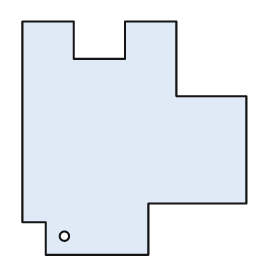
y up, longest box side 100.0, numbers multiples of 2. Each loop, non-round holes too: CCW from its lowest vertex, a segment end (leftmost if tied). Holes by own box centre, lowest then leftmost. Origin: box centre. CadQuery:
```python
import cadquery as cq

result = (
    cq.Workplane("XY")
    .moveTo(-38.0, -50.0)
    .lineTo(6.0, -50.0)
    .lineTo(6.0, -28.0)
    .lineTo(48.0, -28.0)
    .lineTo(48.0, 18.0)
    .lineTo(18.0, 18.0)
    .lineTo(18.0, 50.0)
    .lineTo(-4.0, 50.0)
    .lineTo(-4.0, 34.0)
    .lineTo(-26.0, 34.0)
    .lineTo(-26.0, 50.0)
    .lineTo(-48.0, 50.0)
    .lineTo(-48.0, -36.0)
    .lineTo(-38.0, -36.0)
    .close()
    .moveTo(-30.0, -42.0)
    .circle(2.0)
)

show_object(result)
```